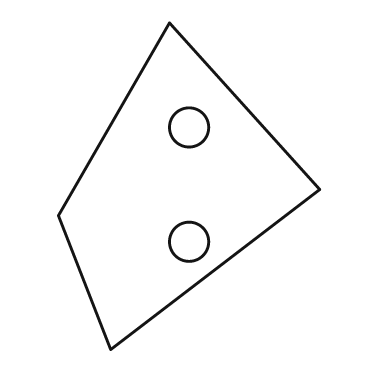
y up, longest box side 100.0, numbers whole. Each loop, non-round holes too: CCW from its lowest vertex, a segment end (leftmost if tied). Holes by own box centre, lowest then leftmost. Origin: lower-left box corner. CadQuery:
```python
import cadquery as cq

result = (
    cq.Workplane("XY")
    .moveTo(16.0, 0.0)
    .lineTo(80.0, 49.0)
    .lineTo(34.0, 100.0)
    .lineTo(0.0, 41.0)
    .close()
    .moveTo(40.0, 33.0)
    .circle(6.0)
    .moveTo(40.0, 68.0)
    .circle(6.0)
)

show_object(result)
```